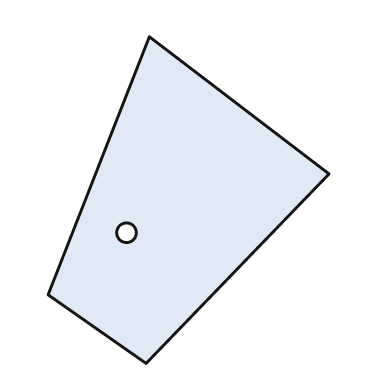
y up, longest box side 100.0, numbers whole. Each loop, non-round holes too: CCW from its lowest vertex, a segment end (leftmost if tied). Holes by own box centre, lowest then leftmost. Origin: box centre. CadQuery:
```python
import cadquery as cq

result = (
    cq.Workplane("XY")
    .moveTo(-13.0, -50.0)
    .lineTo(43.0, 8.0)
    .lineTo(-12.0, 50.0)
    .lineTo(-43.0, -29.0)
    .close()
    .moveTo(-19.0, -10.0)
    .circle(3.0)
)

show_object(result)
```